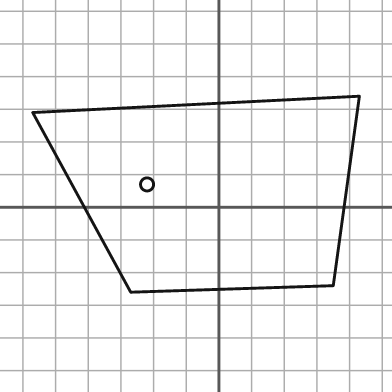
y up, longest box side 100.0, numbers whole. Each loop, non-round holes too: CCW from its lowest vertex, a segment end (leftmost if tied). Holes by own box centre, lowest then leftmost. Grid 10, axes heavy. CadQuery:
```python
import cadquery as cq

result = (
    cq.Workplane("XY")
    .moveTo(-27.0, -26.0)
    .lineTo(35.0, -24.0)
    .lineTo(43.0, 34.0)
    .lineTo(-57.0, 29.0)
    .close()
    .moveTo(-22.0, 7.0)
    .circle(2.0)
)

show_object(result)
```